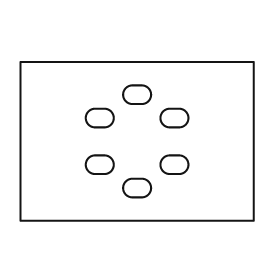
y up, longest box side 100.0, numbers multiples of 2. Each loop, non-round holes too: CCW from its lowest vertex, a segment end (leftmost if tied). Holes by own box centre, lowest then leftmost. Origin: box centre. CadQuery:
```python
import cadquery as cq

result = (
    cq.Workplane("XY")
    .moveTo(-50.0, -34.0)
    .lineTo(50.0, -34.0)
    .lineTo(50.0, 34.0)
    .lineTo(-50.0, 34.0)
    .close()
    .moveTo(-2.0, -24.0)
    .lineTo(2.0, -24.0)
    .threePointArc((6.0, -20.0), (2.0, -16.0))
    .lineTo(-2.0, -16.0)
    .threePointArc((-6.0, -20.0), (-2.0, -24.0))
    .close()
    .moveTo(-18.0, -14.0)
    .lineTo(-14.0, -14.0)
    .threePointArc((-10.0, -10.0), (-14.0, -6.0))
    .lineTo(-18.0, -6.0)
    .threePointArc((-22.0, -10.0), (-18.0, -14.0))
    .close()
    .moveTo(14.0, -14.0)
    .lineTo(18.0, -14.0)
    .threePointArc((22.0, -10.0), (18.0, -6.0))
    .lineTo(14.0, -6.0)
    .threePointArc((10.0, -10.0), (14.0, -14.0))
    .close()
    .moveTo(-18.0, 6.0)
    .lineTo(-14.0, 6.0)
    .threePointArc((-10.0, 10.0), (-14.0, 14.0))
    .lineTo(-18.0, 14.0)
    .threePointArc((-22.0, 10.0), (-18.0, 6.0))
    .close()
    .moveTo(14.0, 6.0)
    .lineTo(18.0, 6.0)
    .threePointArc((22.0, 10.0), (18.0, 14.0))
    .lineTo(14.0, 14.0)
    .threePointArc((10.0, 10.0), (14.0, 6.0))
    .close()
    .moveTo(-2.0, 16.0)
    .lineTo(2.0, 16.0)
    .threePointArc((6.0, 20.0), (2.0, 24.0))
    .lineTo(-2.0, 24.0)
    .threePointArc((-6.0, 20.0), (-2.0, 16.0))
    .close()
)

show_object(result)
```